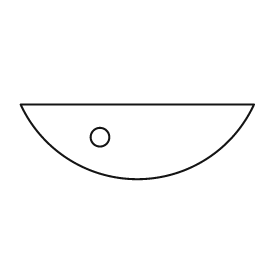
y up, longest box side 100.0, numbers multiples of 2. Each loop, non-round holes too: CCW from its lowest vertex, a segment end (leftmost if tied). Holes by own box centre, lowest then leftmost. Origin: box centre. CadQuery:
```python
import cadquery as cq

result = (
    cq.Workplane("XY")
    .moveTo(-50.0, 16.0)
    .threePointArc((0.0, -16.0), (50.0, 16.0))
    .close()
    .moveTo(-16.0, 2.0)
    .circle(4.0)
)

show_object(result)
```